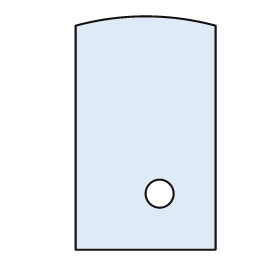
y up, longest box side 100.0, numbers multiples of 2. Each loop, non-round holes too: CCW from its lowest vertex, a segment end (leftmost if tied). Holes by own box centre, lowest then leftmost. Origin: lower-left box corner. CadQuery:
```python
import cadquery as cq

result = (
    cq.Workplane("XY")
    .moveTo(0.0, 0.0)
    .lineTo(60.0, 0.0)
    .lineTo(60.0, 96.0)
    .threePointArc((30.0, 100.0), (0.0, 96.0))
    .close()
    .moveTo(36.0, 24.0)
    .circle(6.0)
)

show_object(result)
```